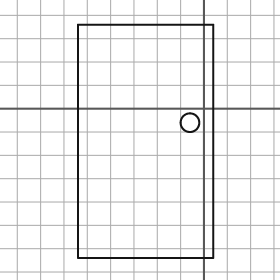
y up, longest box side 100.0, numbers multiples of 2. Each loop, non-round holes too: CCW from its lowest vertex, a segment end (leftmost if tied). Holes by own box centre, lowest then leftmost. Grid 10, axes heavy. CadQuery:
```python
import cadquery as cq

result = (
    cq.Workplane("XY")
    .moveTo(-54.0, -64.0)
    .lineTo(4.0, -64.0)
    .lineTo(4.0, 36.0)
    .lineTo(-54.0, 36.0)
    .close()
    .moveTo(-6.0, -6.0)
    .circle(4.0)
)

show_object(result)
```